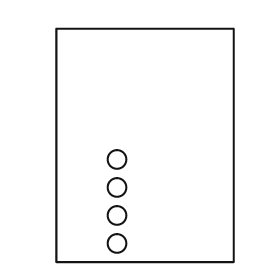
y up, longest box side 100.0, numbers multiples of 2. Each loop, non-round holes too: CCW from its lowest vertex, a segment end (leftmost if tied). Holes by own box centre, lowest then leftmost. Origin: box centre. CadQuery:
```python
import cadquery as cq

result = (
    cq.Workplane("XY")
    .moveTo(-38.0, -50.0)
    .lineTo(38.0, -50.0)
    .lineTo(38.0, 50.0)
    .lineTo(-38.0, 50.0)
    .close()
    .moveTo(-12.0, -42.0)
    .circle(4.0)
    .moveTo(-12.0, -30.0)
    .circle(4.0)
    .moveTo(-12.0, -18.0)
    .circle(4.0)
    .moveTo(-12.0, -6.0)
    .circle(4.0)
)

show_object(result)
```